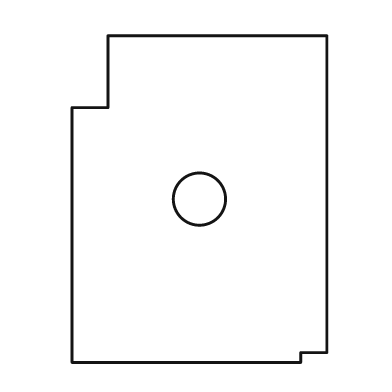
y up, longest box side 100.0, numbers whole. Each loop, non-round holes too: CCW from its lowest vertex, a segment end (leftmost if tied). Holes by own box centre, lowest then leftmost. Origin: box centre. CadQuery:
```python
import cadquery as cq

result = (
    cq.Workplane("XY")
    .moveTo(-39.0, -50.0)
    .lineTo(31.0, -50.0)
    .lineTo(31.0, -47.0)
    .lineTo(39.0, -47.0)
    .lineTo(39.0, 50.0)
    .lineTo(-28.0, 50.0)
    .lineTo(-28.0, 28.0)
    .lineTo(-39.0, 28.0)
    .close()
    .moveTo(0.0, 0.0)
    .circle(8.0)
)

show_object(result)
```